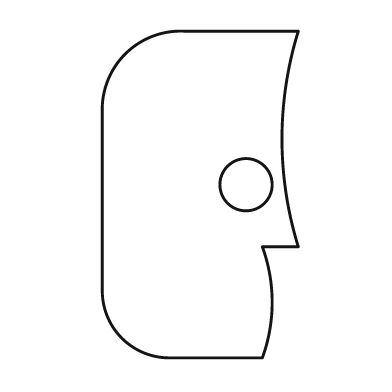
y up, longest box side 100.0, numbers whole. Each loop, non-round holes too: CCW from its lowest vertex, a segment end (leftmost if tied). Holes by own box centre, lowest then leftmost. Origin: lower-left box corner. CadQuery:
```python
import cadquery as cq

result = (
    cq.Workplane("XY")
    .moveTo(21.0, 0.0)
    .lineTo(49.0, 0.0)
    .threePointArc((52.0, 17.0), (49.0, 34.0))
    .lineTo(60.0, 34.0)
    .threePointArc((55.0, 67.0), (60.0, 100.0))
    .lineTo(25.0, 100.0)
    .threePointArc((7.0, 93.0), (0.0, 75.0))
    .lineTo(0.0, 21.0)
    .threePointArc((6.0, 6.0), (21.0, 0.0))
    .close()
    .moveTo(44.0, 53.0)
    .circle(8.0)
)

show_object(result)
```